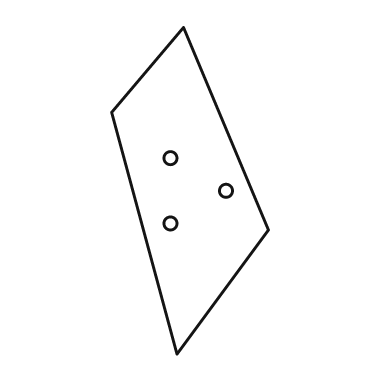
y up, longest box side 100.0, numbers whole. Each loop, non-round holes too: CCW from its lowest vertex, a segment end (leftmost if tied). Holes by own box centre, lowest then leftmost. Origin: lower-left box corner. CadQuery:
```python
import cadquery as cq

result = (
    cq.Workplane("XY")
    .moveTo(20.0, 0.0)
    .lineTo(48.0, 38.0)
    .lineTo(22.0, 100.0)
    .lineTo(0.0, 74.0)
    .close()
    .moveTo(18.0, 40.0)
    .circle(2.0)
    .moveTo(35.0, 50.0)
    .circle(2.0)
    .moveTo(18.0, 60.0)
    .circle(2.0)
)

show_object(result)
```